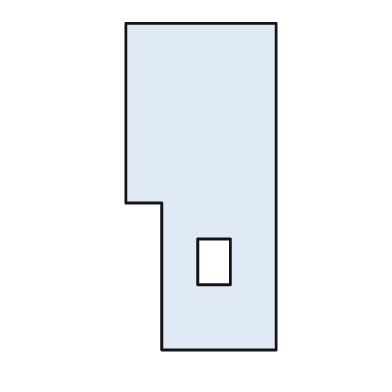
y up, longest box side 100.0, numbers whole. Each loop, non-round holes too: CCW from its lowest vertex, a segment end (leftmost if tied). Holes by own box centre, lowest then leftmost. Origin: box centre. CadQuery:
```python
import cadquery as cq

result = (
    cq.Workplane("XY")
    .moveTo(-12.0, -50.0)
    .lineTo(23.0, -50.0)
    .lineTo(23.0, 50.0)
    .lineTo(-23.0, 50.0)
    .lineTo(-23.0, -5.0)
    .lineTo(-12.0, -5.0)
    .close()
    .moveTo(-1.0, -30.0)
    .lineTo(9.0, -30.0)
    .lineTo(9.0, -16.0)
    .lineTo(-1.0, -16.0)
    .close()
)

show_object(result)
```